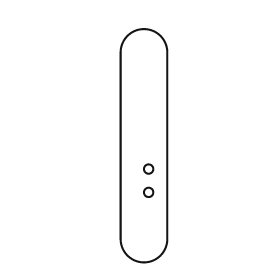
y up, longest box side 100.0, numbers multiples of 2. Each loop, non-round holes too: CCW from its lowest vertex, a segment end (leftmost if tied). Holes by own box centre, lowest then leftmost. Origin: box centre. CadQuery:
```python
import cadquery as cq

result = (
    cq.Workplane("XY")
    .moveTo(-10.0, -40.0)
    .threePointArc((0.0, -50.0), (10.0, -40.0))
    .lineTo(10.0, 40.0)
    .threePointArc((0.0, 50.0), (-10.0, 40.0))
    .close()
    .moveTo(2.0, -20.0)
    .circle(2.0)
    .moveTo(2.0, -10.0)
    .circle(2.0)
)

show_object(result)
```